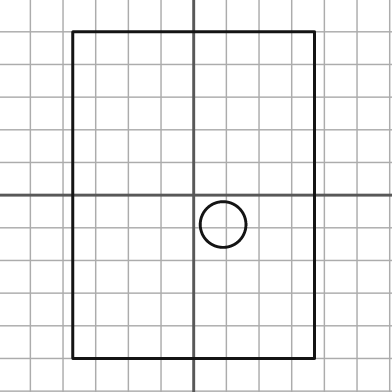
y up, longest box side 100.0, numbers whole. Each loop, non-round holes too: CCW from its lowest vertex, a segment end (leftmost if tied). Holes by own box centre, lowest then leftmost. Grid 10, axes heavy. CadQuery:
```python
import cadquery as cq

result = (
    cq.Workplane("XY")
    .moveTo(-37.0, -50.0)
    .lineTo(37.0, -50.0)
    .lineTo(37.0, 50.0)
    .lineTo(-37.0, 50.0)
    .close()
    .moveTo(9.0, -9.0)
    .circle(7.0)
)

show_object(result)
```